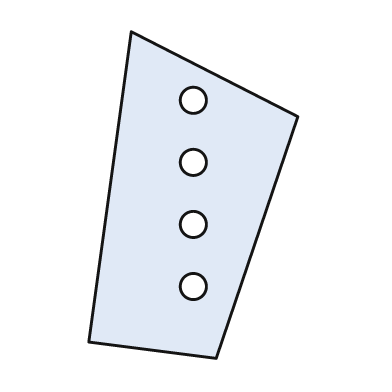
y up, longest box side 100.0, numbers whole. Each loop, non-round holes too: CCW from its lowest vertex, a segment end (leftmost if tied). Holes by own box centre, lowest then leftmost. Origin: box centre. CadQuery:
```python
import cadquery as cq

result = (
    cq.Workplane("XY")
    .moveTo(7.0, -50.0)
    .lineTo(32.0, 24.0)
    .lineTo(-19.0, 50.0)
    .lineTo(-32.0, -45.0)
    .close()
    .moveTo(0.0, -28.0)
    .circle(4.0)
    .moveTo(0.0, -9.0)
    .circle(4.0)
    .moveTo(0.0, 10.0)
    .circle(4.0)
    .moveTo(0.0, 29.0)
    .circle(4.0)
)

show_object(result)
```